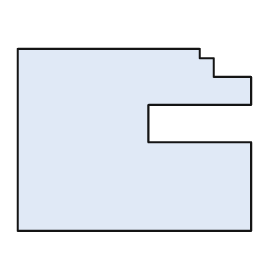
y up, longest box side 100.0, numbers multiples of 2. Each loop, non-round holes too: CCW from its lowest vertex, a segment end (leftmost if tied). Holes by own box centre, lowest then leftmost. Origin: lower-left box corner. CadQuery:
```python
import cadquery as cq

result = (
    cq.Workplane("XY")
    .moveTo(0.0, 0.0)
    .lineTo(100.0, 0.0)
    .lineTo(100.0, 38.0)
    .lineTo(56.0, 38.0)
    .lineTo(56.0, 54.0)
    .lineTo(100.0, 54.0)
    .lineTo(100.0, 66.0)
    .lineTo(84.0, 66.0)
    .lineTo(84.0, 74.0)
    .lineTo(78.0, 74.0)
    .lineTo(78.0, 78.0)
    .lineTo(0.0, 78.0)
    .close()
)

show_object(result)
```